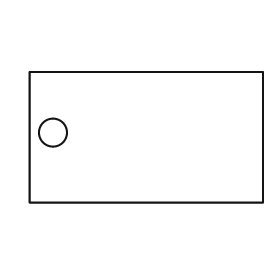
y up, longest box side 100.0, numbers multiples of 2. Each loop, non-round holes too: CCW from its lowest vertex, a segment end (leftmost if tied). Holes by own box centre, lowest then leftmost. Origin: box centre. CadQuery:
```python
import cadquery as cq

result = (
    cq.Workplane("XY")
    .moveTo(-50.0, -28.0)
    .lineTo(50.0, -28.0)
    .lineTo(50.0, 28.0)
    .lineTo(-50.0, 28.0)
    .close()
    .moveTo(-40.0, 2.0)
    .circle(6.0)
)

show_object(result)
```